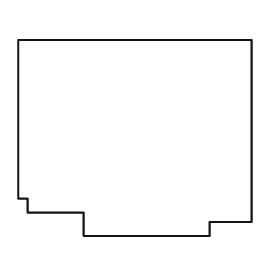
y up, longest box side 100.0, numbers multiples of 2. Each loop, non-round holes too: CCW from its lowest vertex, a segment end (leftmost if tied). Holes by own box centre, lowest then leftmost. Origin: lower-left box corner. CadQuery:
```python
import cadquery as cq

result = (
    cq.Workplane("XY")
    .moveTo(28.0, 0.0)
    .lineTo(82.0, 0.0)
    .lineTo(82.0, 6.0)
    .lineTo(100.0, 6.0)
    .lineTo(100.0, 84.0)
    .lineTo(0.0, 84.0)
    .lineTo(0.0, 16.0)
    .lineTo(4.0, 16.0)
    .lineTo(4.0, 10.0)
    .lineTo(28.0, 10.0)
    .close()
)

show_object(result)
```